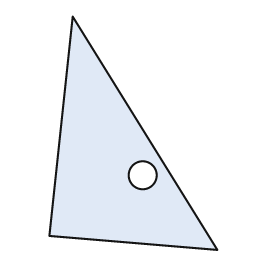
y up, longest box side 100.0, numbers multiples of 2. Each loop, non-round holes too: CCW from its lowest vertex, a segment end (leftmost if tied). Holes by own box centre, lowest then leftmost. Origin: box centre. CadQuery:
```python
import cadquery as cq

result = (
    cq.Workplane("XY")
    .moveTo(36.0, -50.0)
    .lineTo(-26.0, 50.0)
    .lineTo(-36.0, -44.0)
    .close()
    .moveTo(4.0, -18.0)
    .circle(6.0)
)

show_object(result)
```